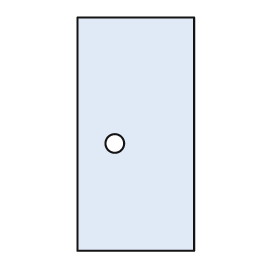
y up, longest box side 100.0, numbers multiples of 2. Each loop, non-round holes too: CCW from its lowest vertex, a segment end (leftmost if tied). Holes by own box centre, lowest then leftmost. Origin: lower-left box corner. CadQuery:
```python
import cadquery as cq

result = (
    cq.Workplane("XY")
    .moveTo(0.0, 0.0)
    .lineTo(50.0, 0.0)
    .lineTo(50.0, 100.0)
    .lineTo(0.0, 100.0)
    .close()
    .moveTo(16.0, 46.0)
    .circle(4.0)
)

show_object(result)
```